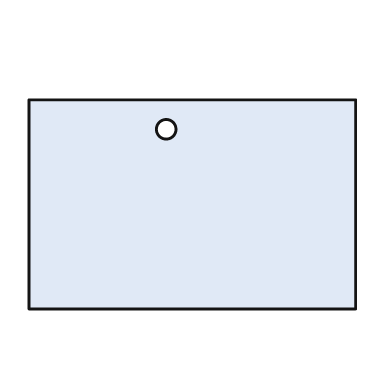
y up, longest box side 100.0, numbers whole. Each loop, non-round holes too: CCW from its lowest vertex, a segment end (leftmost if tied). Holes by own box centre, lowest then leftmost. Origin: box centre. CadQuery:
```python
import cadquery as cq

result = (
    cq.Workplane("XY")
    .moveTo(-50.0, -32.0)
    .lineTo(50.0, -32.0)
    .lineTo(50.0, 32.0)
    .lineTo(-50.0, 32.0)
    .close()
    .moveTo(-8.0, 23.0)
    .circle(3.0)
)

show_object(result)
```